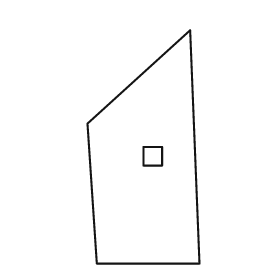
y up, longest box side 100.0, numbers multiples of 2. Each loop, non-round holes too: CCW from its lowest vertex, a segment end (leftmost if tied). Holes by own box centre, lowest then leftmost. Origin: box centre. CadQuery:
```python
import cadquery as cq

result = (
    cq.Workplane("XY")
    .moveTo(-20.0, -50.0)
    .lineTo(24.0, -50.0)
    .lineTo(20.0, 50.0)
    .lineTo(-24.0, 10.0)
    .close()
    .moveTo(0.0, -8.0)
    .lineTo(8.0, -8.0)
    .lineTo(8.0, 0.0)
    .lineTo(0.0, 0.0)
    .close()
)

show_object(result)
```